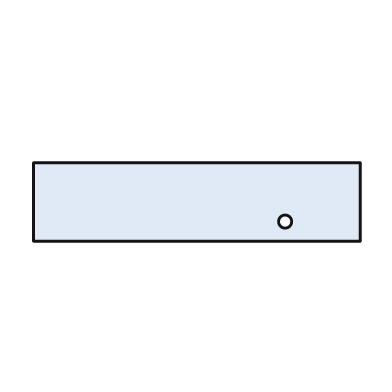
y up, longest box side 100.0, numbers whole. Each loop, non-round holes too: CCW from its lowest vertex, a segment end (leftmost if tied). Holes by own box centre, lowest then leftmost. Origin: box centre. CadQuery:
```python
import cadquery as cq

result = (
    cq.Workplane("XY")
    .moveTo(-50.0, -12.0)
    .lineTo(50.0, -12.0)
    .lineTo(50.0, 12.0)
    .lineTo(-50.0, 12.0)
    .close()
    .moveTo(27.0, -6.0)
    .circle(2.0)
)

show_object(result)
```